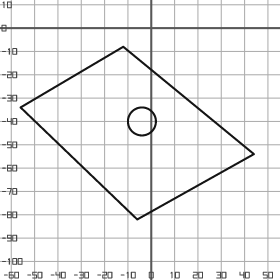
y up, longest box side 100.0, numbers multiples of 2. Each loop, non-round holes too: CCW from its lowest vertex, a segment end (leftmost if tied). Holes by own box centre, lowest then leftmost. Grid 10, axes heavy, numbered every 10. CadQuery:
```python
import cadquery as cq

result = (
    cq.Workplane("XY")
    .moveTo(-6.0, -82.0)
    .lineTo(44.0, -54.0)
    .lineTo(-12.0, -8.0)
    .lineTo(-56.0, -34.0)
    .close()
    .moveTo(-4.0, -40.0)
    .circle(6.0)
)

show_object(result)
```